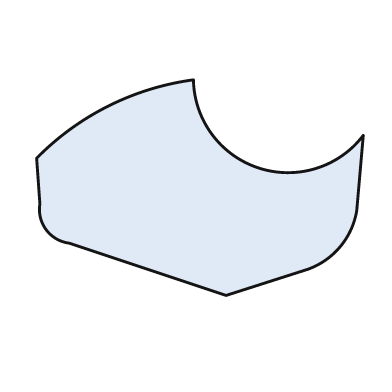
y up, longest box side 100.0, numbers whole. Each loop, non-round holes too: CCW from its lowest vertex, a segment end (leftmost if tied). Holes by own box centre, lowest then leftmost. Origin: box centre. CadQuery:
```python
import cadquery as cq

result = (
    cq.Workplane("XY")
    .moveTo(8.0, -33.0)
    .lineTo(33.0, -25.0)
    .threePointArc((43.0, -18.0), (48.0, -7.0))
    .lineTo(50.0, 16.0)
    .threePointArc((18.0, 6.0), (-2.0, 33.0))
    .threePointArc((-28.0, 25.0), (-50.0, 9.0))
    .lineTo(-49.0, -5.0)
    .threePointArc((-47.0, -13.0), (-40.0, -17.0))
    .close()
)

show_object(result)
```